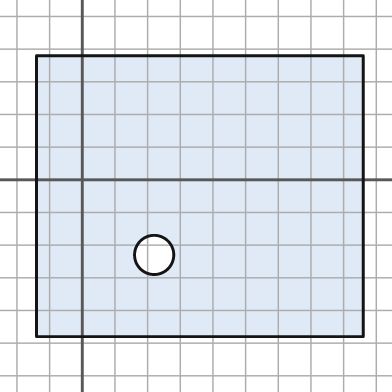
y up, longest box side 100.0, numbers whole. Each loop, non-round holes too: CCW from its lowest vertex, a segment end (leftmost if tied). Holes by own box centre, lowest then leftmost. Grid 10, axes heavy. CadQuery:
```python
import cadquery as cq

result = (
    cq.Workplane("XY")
    .moveTo(-14.0, -48.0)
    .lineTo(86.0, -48.0)
    .lineTo(86.0, 38.0)
    .lineTo(-14.0, 38.0)
    .close()
    .moveTo(22.0, -23.0)
    .circle(6.0)
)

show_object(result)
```